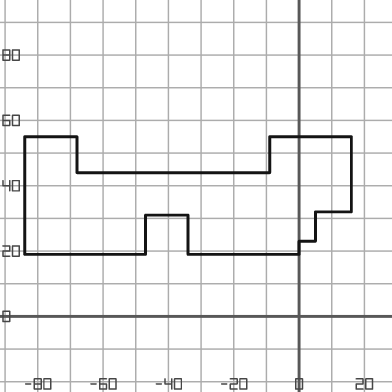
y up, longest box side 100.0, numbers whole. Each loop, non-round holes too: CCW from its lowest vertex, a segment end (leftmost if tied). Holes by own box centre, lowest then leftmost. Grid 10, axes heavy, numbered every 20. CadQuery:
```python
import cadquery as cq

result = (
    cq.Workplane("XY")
    .moveTo(-84.0, 19.0)
    .lineTo(-47.0, 19.0)
    .lineTo(-47.0, 31.0)
    .lineTo(-34.0, 31.0)
    .lineTo(-34.0, 19.0)
    .lineTo(0.0, 19.0)
    .lineTo(0.0, 23.0)
    .lineTo(5.0, 23.0)
    .lineTo(5.0, 32.0)
    .lineTo(16.0, 32.0)
    .lineTo(16.0, 55.0)
    .lineTo(-9.0, 55.0)
    .lineTo(-9.0, 44.0)
    .lineTo(-68.0, 44.0)
    .lineTo(-68.0, 55.0)
    .lineTo(-84.0, 55.0)
    .close()
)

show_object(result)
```